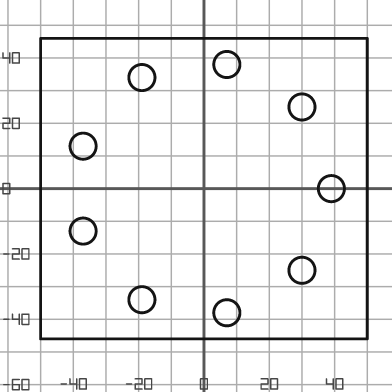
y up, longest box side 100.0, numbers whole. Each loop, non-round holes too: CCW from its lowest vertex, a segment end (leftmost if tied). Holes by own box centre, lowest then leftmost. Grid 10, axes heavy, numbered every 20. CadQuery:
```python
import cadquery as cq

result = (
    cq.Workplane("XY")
    .moveTo(-50.0, -46.0)
    .lineTo(50.0, -46.0)
    .lineTo(50.0, 46.0)
    .lineTo(-50.0, 46.0)
    .close()
    .moveTo(7.0, -38.0)
    .circle(4.0)
    .moveTo(-19.0, -34.0)
    .circle(4.0)
    .moveTo(30.0, -25.0)
    .circle(4.0)
    .moveTo(-37.0, -13.0)
    .circle(4.0)
    .moveTo(39.0, 0.0)
    .circle(4.0)
    .moveTo(-37.0, 13.0)
    .circle(4.0)
    .moveTo(30.0, 25.0)
    .circle(4.0)
    .moveTo(-19.0, 34.0)
    .circle(4.0)
    .moveTo(7.0, 38.0)
    .circle(4.0)
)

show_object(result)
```